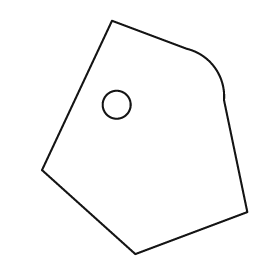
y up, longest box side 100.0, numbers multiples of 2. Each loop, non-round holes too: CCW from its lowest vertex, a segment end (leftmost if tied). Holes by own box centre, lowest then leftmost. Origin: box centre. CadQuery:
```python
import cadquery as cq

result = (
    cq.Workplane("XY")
    .moveTo(-4.0, -50.0)
    .lineTo(44.0, -32.0)
    .lineTo(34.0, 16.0)
    .threePointArc((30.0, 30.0), (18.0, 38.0))
    .lineTo(-14.0, 50.0)
    .lineTo(-44.0, -14.0)
    .close()
    .moveTo(-12.0, 14.0)
    .circle(6.0)
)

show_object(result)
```